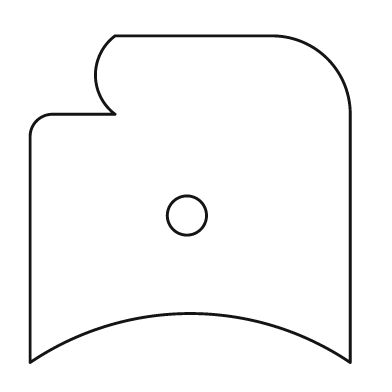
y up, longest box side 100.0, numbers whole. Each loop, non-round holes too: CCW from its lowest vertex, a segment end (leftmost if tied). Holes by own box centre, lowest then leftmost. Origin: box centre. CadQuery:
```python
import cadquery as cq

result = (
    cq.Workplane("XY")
    .moveTo(-49.0, -50.0)
    .threePointArc((0.0, -35.0), (49.0, -50.0))
    .lineTo(49.0, 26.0)
    .threePointArc((42.0, 43.0), (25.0, 50.0))
    .lineTo(-23.0, 50.0)
    .threePointArc((-29.0, 38.0), (-23.0, 26.0))
    .lineTo(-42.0, 26.0)
    .threePointArc((-47.0, 24.0), (-49.0, 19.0))
    .close()
    .moveTo(-1.0, -5.0)
    .circle(6.0)
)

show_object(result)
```